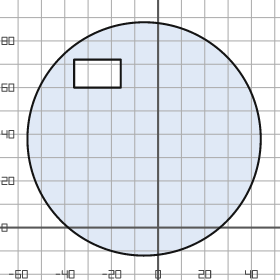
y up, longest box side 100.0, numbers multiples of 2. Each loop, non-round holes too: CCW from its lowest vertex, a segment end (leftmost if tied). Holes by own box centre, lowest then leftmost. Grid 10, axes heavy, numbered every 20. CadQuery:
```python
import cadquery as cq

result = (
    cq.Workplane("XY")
    .moveTo(-6.0, 38.0)
    .circle(50.0)
    .moveTo(-36.0, 60.0)
    .lineTo(-16.0, 60.0)
    .lineTo(-16.0, 72.0)
    .lineTo(-36.0, 72.0)
    .close()
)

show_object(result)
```